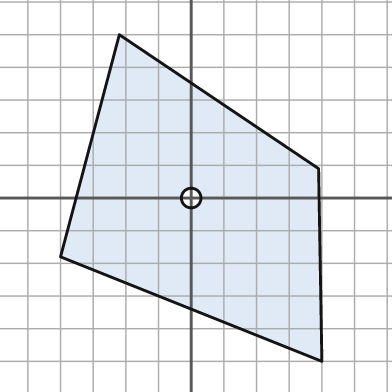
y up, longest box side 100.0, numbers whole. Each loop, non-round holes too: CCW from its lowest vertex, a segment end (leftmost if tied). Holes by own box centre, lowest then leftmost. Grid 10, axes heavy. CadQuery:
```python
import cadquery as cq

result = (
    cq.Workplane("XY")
    .moveTo(40.0, -50.0)
    .lineTo(39.0, 9.0)
    .lineTo(-22.0, 50.0)
    .lineTo(-40.0, -18.0)
    .close()
    .moveTo(0.0, 0.0)
    .circle(3.0)
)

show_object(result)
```